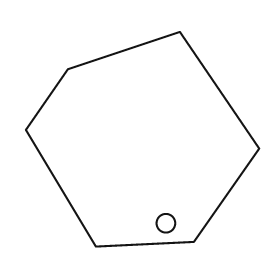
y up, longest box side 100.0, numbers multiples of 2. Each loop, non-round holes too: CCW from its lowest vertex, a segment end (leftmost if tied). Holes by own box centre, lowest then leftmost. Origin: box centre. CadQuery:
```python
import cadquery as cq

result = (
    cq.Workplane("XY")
    .moveTo(-20.0, -46.0)
    .lineTo(22.0, -44.0)
    .lineTo(50.0, -4.0)
    .lineTo(16.0, 46.0)
    .lineTo(-32.0, 30.0)
    .lineTo(-50.0, 4.0)
    .close()
    .moveTo(10.0, -36.0)
    .circle(4.0)
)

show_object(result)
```